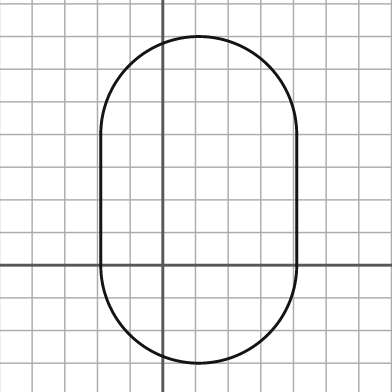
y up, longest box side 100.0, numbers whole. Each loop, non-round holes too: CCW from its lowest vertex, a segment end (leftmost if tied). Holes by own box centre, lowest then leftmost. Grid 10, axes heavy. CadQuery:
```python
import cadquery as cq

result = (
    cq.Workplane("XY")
    .moveTo(-19.0, 0.0)
    .threePointArc((11.0, -30.0), (41.0, 0.0))
    .lineTo(41.0, 40.0)
    .threePointArc((11.0, 70.0), (-19.0, 40.0))
    .close()
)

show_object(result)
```